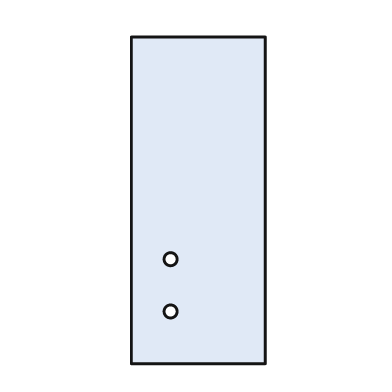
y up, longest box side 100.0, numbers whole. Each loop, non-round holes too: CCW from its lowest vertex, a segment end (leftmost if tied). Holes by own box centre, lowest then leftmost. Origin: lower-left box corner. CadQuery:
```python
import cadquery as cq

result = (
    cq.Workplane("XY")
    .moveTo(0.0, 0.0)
    .lineTo(41.0, 0.0)
    .lineTo(41.0, 100.0)
    .lineTo(0.0, 100.0)
    .close()
    .moveTo(12.0, 16.0)
    .circle(2.0)
    .moveTo(12.0, 32.0)
    .circle(2.0)
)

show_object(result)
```